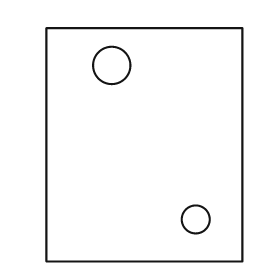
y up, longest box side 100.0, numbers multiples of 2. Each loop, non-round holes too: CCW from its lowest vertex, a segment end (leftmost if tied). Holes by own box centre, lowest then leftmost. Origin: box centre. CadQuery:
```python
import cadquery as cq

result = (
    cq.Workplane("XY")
    .moveTo(-42.0, -50.0)
    .lineTo(42.0, -50.0)
    .lineTo(42.0, 50.0)
    .lineTo(-42.0, 50.0)
    .close()
    .moveTo(22.0, -32.0)
    .circle(6.0)
    .moveTo(-14.0, 34.0)
    .circle(8.0)
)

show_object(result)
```